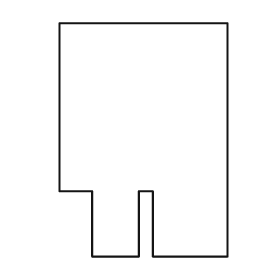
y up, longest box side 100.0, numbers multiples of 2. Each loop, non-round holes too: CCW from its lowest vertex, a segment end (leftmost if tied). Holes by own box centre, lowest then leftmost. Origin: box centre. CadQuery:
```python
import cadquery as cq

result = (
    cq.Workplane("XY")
    .moveTo(-22.0, -50.0)
    .lineTo(-2.0, -50.0)
    .lineTo(-2.0, -22.0)
    .lineTo(4.0, -22.0)
    .lineTo(4.0, -50.0)
    .lineTo(36.0, -50.0)
    .lineTo(36.0, 50.0)
    .lineTo(-36.0, 50.0)
    .lineTo(-36.0, -22.0)
    .lineTo(-22.0, -22.0)
    .close()
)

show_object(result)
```